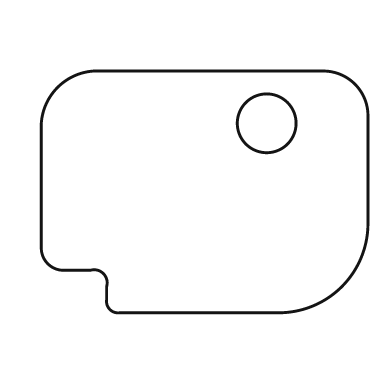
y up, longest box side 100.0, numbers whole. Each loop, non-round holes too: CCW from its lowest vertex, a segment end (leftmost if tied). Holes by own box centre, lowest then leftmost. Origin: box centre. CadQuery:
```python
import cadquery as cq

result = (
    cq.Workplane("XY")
    .moveTo(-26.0, -37.0)
    .lineTo(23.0, -37.0)
    .threePointArc((42.0, -29.0), (50.0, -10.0))
    .lineTo(50.0, 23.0)
    .threePointArc((46.0, 33.0), (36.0, 37.0))
    .lineTo(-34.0, 37.0)
    .threePointArc((-45.0, 32.0), (-50.0, 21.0))
    .lineTo(-50.0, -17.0)
    .threePointArc((-48.0, -22.0), (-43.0, -24.0))
    .lineTo(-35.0, -24.0)
    .threePointArc((-31.0, -25.0), (-30.0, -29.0))
    .lineTo(-30.0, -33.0)
    .threePointArc((-29.0, -36.0), (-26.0, -37.0))
    .close()
    .moveTo(19.0, 21.0)
    .circle(9.0)
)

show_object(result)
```